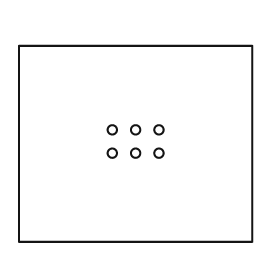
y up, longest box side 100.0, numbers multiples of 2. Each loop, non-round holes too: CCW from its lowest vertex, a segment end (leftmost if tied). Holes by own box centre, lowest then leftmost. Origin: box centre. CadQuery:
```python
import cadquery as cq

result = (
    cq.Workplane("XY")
    .moveTo(-50.0, -42.0)
    .lineTo(50.0, -42.0)
    .lineTo(50.0, 42.0)
    .lineTo(-50.0, 42.0)
    .close()
    .moveTo(-10.0, -4.0)
    .circle(2.0)
    .moveTo(0.0, -4.0)
    .circle(2.0)
    .moveTo(10.0, -4.0)
    .circle(2.0)
    .moveTo(-10.0, 6.0)
    .circle(2.0)
    .moveTo(0.0, 6.0)
    .circle(2.0)
    .moveTo(10.0, 6.0)
    .circle(2.0)
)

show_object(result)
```